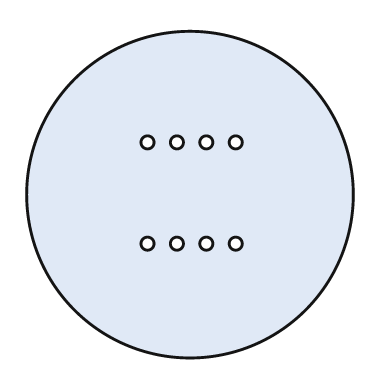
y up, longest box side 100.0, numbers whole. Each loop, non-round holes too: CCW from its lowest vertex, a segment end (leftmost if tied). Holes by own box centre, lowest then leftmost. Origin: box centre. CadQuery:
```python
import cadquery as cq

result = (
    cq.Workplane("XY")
    .moveTo(0.0, 0.0)
    .circle(50.0)
    .moveTo(-13.0, -15.0)
    .circle(2.0)
    .moveTo(-4.0, -15.0)
    .circle(2.0)
    .moveTo(5.0, -15.0)
    .circle(2.0)
    .moveTo(14.0, -15.0)
    .circle(2.0)
    .moveTo(-13.0, 16.0)
    .circle(2.0)
    .moveTo(-4.0, 16.0)
    .circle(2.0)
    .moveTo(5.0, 16.0)
    .circle(2.0)
    .moveTo(14.0, 16.0)
    .circle(2.0)
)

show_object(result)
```